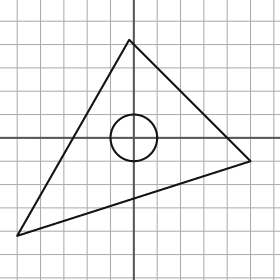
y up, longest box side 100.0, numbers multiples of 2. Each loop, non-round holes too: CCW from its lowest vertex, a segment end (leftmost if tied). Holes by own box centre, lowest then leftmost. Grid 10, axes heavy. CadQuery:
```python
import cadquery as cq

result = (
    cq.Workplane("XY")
    .moveTo(-50.0, -42.0)
    .lineTo(50.0, -10.0)
    .lineTo(-2.0, 42.0)
    .close()
    .moveTo(0.0, 0.0)
    .circle(10.0)
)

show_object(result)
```